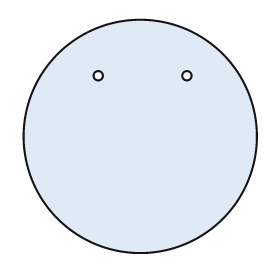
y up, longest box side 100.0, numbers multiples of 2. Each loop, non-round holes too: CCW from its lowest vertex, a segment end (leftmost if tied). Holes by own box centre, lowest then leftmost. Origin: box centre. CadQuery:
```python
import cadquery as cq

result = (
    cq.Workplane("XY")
    .moveTo(0.0, 0.0)
    .circle(50.0)
    .moveTo(-18.0, 26.0)
    .circle(2.0)
    .moveTo(20.0, 26.0)
    .circle(2.0)
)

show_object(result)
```